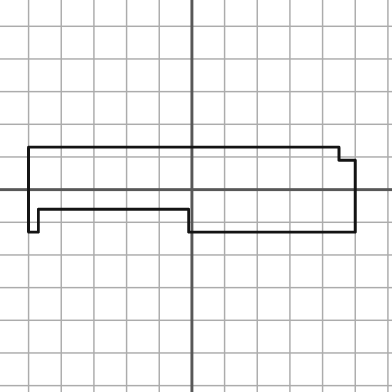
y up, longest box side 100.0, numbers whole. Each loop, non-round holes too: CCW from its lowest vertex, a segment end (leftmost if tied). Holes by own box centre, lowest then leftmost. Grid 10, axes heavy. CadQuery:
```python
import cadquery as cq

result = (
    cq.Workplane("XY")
    .moveTo(-50.0, -13.0)
    .lineTo(-47.0, -13.0)
    .lineTo(-47.0, -6.0)
    .lineTo(-1.0, -6.0)
    .lineTo(-1.0, -13.0)
    .lineTo(50.0, -13.0)
    .lineTo(50.0, 9.0)
    .lineTo(45.0, 9.0)
    .lineTo(45.0, 13.0)
    .lineTo(-50.0, 13.0)
    .close()
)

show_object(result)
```